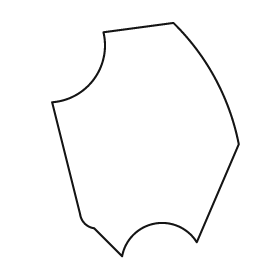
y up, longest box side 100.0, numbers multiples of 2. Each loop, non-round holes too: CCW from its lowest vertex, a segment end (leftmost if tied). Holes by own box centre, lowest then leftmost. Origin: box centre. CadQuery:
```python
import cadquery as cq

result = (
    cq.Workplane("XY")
    .moveTo(-10.0, -50.0)
    .threePointArc((4.0, -36.0), (22.0, -44.0))
    .lineTo(40.0, -2.0)
    .threePointArc((30.0, 26.0), (12.0, 50.0))
    .lineTo(-18.0, 46.0)
    .threePointArc((-22.0, 26.0), (-40.0, 16.0))
    .lineTo(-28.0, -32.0)
    .threePointArc((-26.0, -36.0), (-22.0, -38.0))
    .close()
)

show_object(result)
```